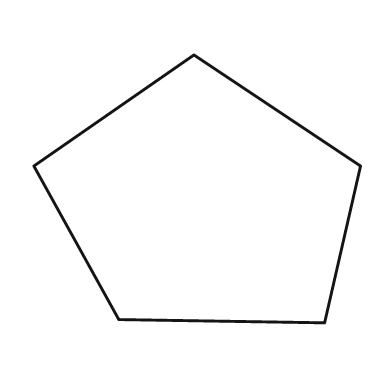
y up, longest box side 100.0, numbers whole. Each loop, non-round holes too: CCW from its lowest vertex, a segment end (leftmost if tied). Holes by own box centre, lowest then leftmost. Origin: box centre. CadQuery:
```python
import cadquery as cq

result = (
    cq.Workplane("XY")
    .moveTo(39.0, -41.0)
    .lineTo(50.0, 7.0)
    .lineTo(-1.0, 41.0)
    .lineTo(-50.0, 7.0)
    .lineTo(-24.0, -40.0)
    .close()
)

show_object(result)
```